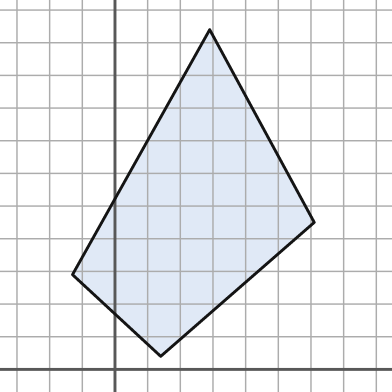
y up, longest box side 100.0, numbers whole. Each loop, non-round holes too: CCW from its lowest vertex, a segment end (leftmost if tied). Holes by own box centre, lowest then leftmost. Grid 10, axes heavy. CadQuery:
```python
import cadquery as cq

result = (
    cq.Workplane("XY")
    .moveTo(14.0, 4.0)
    .lineTo(61.0, 45.0)
    .lineTo(29.0, 104.0)
    .lineTo(-13.0, 29.0)
    .close()
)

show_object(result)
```